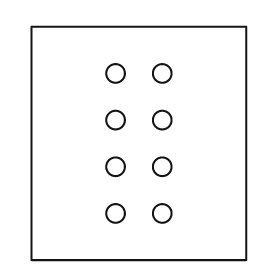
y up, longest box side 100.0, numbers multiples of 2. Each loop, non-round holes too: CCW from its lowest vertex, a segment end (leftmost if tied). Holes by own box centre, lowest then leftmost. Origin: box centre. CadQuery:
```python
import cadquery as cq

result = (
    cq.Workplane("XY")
    .moveTo(-46.0, -50.0)
    .lineTo(46.0, -50.0)
    .lineTo(46.0, 50.0)
    .lineTo(-46.0, 50.0)
    .close()
    .moveTo(-10.0, -30.0)
    .circle(4.0)
    .moveTo(10.0, -30.0)
    .circle(4.0)
    .moveTo(-10.0, -10.0)
    .circle(4.0)
    .moveTo(10.0, -10.0)
    .circle(4.0)
    .moveTo(-10.0, 10.0)
    .circle(4.0)
    .moveTo(10.0, 10.0)
    .circle(4.0)
    .moveTo(-10.0, 30.0)
    .circle(4.0)
    .moveTo(10.0, 30.0)
    .circle(4.0)
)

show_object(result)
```